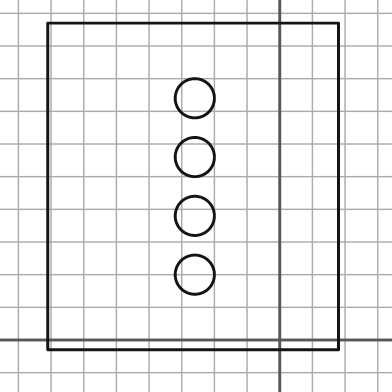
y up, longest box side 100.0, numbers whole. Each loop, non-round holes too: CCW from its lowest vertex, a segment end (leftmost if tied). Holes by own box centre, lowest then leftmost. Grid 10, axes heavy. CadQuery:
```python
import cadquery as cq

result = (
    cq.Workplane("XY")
    .moveTo(-71.0, -3.0)
    .lineTo(18.0, -3.0)
    .lineTo(18.0, 97.0)
    .lineTo(-71.0, 97.0)
    .close()
    .moveTo(-26.0, 20.0)
    .circle(6.0)
    .moveTo(-26.0, 38.0)
    .circle(6.0)
    .moveTo(-26.0, 56.0)
    .circle(6.0)
    .moveTo(-26.0, 74.0)
    .circle(6.0)
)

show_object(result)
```